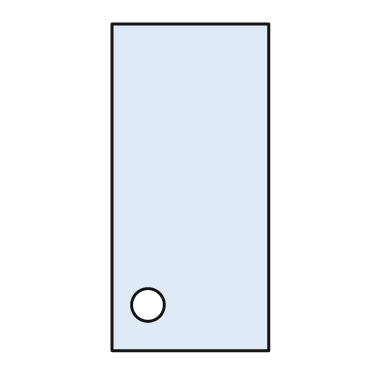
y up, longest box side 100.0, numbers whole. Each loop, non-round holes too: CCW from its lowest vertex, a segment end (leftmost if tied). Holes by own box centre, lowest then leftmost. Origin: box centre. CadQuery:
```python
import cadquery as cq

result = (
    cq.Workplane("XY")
    .moveTo(-24.0, -50.0)
    .lineTo(24.0, -50.0)
    .lineTo(24.0, 50.0)
    .lineTo(-24.0, 50.0)
    .close()
    .moveTo(-13.0, -36.0)
    .circle(5.0)
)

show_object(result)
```